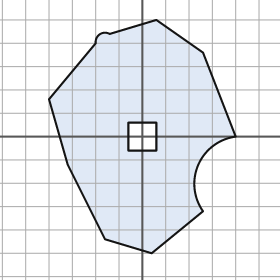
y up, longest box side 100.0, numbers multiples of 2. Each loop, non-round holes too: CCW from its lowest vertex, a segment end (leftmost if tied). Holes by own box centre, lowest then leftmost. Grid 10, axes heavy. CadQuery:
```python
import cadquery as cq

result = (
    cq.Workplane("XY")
    .moveTo(4.0, -50.0)
    .lineTo(26.0, -32.0)
    .threePointArc((24.0, -12.0), (40.0, 0.0))
    .lineTo(26.0, 36.0)
    .lineTo(6.0, 50.0)
    .lineTo(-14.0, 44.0)
    .threePointArc((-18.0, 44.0), (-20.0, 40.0))
    .lineTo(-40.0, 16.0)
    .lineTo(-32.0, -12.0)
    .lineTo(-16.0, -44.0)
    .close()
    .moveTo(-6.0, -6.0)
    .lineTo(6.0, -6.0)
    .lineTo(6.0, 6.0)
    .lineTo(-6.0, 6.0)
    .close()
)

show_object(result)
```